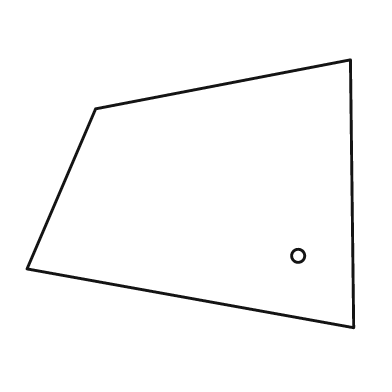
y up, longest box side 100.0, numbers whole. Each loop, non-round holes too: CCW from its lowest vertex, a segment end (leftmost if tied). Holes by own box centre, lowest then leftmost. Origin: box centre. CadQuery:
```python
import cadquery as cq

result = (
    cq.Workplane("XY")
    .moveTo(50.0, -41.0)
    .lineTo(49.0, 41.0)
    .lineTo(-29.0, 26.0)
    .lineTo(-50.0, -23.0)
    .close()
    .moveTo(33.0, -19.0)
    .circle(2.0)
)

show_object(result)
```